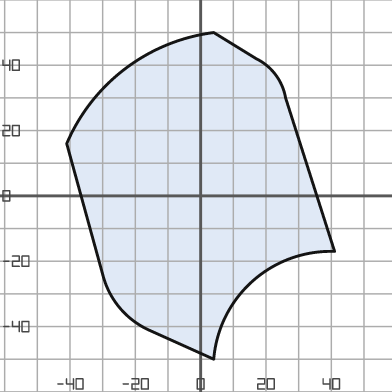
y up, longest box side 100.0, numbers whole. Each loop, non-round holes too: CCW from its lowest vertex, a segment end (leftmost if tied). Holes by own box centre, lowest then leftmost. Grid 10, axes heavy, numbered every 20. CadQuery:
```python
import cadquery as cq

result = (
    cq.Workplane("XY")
    .moveTo(4.0, -50.0)
    .threePointArc((16.0, -26.0), (41.0, -17.0))
    .lineTo(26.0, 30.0)
    .threePointArc((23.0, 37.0), (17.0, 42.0))
    .lineTo(4.0, 50.0)
    .threePointArc((-23.0, 39.0), (-41.0, 16.0))
    .lineTo(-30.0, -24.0)
    .threePointArc((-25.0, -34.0), (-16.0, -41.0))
    .close()
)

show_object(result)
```